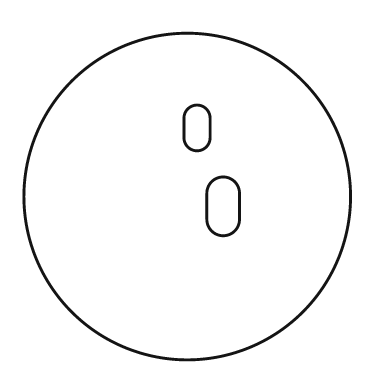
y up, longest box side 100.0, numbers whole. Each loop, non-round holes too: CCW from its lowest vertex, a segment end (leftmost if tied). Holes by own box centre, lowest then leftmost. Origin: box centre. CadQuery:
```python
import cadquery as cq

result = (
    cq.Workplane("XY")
    .moveTo(0.0, 0.0)
    .circle(50.0)
    .moveTo(6.0, -7.0)
    .threePointArc((11.0, -12.0), (16.0, -7.0))
    .lineTo(16.0, 1.0)
    .threePointArc((11.0, 6.0), (6.0, 1.0))
    .close()
    .moveTo(-1.0, 18.0)
    .threePointArc((3.0, 14.0), (7.0, 18.0))
    .lineTo(7.0, 24.0)
    .threePointArc((3.0, 28.0), (-1.0, 24.0))
    .close()
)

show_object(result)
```